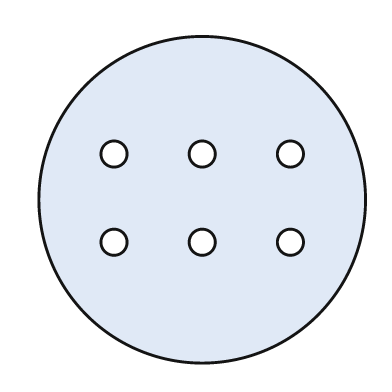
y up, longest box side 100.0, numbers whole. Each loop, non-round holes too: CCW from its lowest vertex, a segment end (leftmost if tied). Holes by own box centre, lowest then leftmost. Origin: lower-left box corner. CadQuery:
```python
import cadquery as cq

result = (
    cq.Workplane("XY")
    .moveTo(50.0, 50.0)
    .circle(50.0)
    .moveTo(23.0, 37.0)
    .circle(4.0)
    .moveTo(50.0, 37.0)
    .circle(4.0)
    .moveTo(77.0, 37.0)
    .circle(4.0)
    .moveTo(23.0, 64.0)
    .circle(4.0)
    .moveTo(50.0, 64.0)
    .circle(4.0)
    .moveTo(77.0, 64.0)
    .circle(4.0)
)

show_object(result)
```